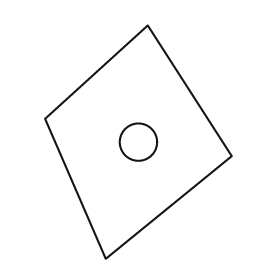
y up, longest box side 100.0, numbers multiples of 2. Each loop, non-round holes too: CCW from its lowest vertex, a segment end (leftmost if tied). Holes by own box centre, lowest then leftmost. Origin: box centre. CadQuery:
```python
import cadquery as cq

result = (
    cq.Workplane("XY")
    .moveTo(-14.0, -50.0)
    .lineTo(40.0, -6.0)
    .lineTo(4.0, 50.0)
    .lineTo(-40.0, 10.0)
    .close()
    .moveTo(0.0, 0.0)
    .circle(8.0)
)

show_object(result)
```